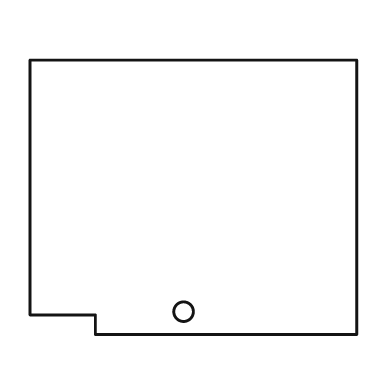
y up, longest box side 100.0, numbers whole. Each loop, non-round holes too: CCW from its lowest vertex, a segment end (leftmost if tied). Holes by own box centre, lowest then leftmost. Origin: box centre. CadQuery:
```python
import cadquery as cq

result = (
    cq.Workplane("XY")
    .moveTo(-30.0, -42.0)
    .lineTo(50.0, -42.0)
    .lineTo(50.0, 42.0)
    .lineTo(-50.0, 42.0)
    .lineTo(-50.0, -36.0)
    .lineTo(-30.0, -36.0)
    .close()
    .moveTo(-3.0, -35.0)
    .circle(3.0)
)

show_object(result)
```